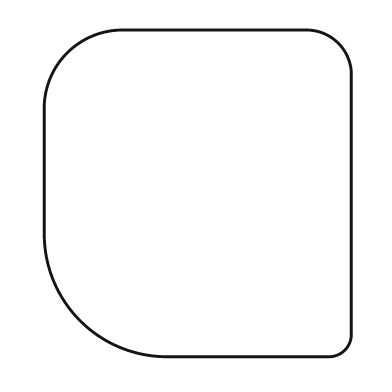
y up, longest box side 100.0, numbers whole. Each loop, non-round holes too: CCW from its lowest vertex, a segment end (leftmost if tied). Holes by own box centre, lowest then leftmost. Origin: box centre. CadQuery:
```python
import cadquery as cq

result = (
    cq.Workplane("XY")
    .moveTo(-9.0, -50.0)
    .lineTo(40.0, -50.0)
    .threePointArc((45.0, -48.0), (47.0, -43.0))
    .lineTo(47.0, 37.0)
    .threePointArc((43.0, 46.0), (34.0, 50.0))
    .lineTo(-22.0, 50.0)
    .threePointArc((-40.0, 43.0), (-47.0, 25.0))
    .lineTo(-47.0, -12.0)
    .threePointArc((-36.0, -39.0), (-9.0, -50.0))
    .close()
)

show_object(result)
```